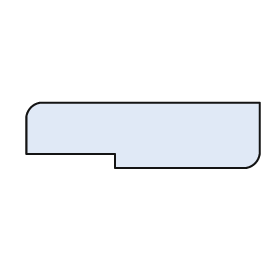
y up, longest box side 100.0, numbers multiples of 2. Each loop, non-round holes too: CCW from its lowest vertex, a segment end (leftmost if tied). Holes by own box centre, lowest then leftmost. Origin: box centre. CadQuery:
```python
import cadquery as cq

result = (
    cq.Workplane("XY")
    .moveTo(-12.0, -14.0)
    .lineTo(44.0, -14.0)
    .threePointArc((48.0, -12.0), (50.0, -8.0))
    .lineTo(50.0, 14.0)
    .lineTo(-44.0, 14.0)
    .threePointArc((-48.0, 12.0), (-50.0, 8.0))
    .lineTo(-50.0, -8.0)
    .lineTo(-12.0, -8.0)
    .close()
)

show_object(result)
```